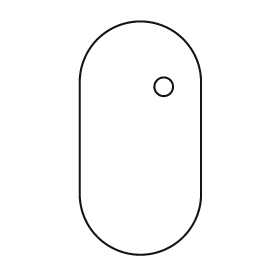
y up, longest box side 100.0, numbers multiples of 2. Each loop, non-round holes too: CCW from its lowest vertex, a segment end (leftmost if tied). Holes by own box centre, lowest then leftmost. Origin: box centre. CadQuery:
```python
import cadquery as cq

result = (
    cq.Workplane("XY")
    .moveTo(-26.0, -24.0)
    .threePointArc((0.0, -50.0), (26.0, -24.0))
    .lineTo(26.0, 24.0)
    .threePointArc((0.0, 50.0), (-26.0, 24.0))
    .close()
    .moveTo(10.0, 22.0)
    .circle(4.0)
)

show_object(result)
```